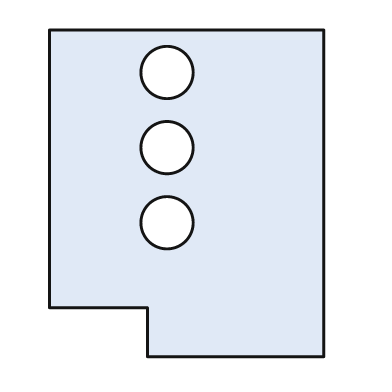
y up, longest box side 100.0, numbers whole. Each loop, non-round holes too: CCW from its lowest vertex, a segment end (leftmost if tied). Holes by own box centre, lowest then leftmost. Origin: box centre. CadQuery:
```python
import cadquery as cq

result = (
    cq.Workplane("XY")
    .moveTo(-12.0, -50.0)
    .lineTo(42.0, -50.0)
    .lineTo(42.0, 50.0)
    .lineTo(-42.0, 50.0)
    .lineTo(-42.0, -35.0)
    .lineTo(-12.0, -35.0)
    .close()
    .moveTo(-6.0, -9.0)
    .circle(8.0)
    .moveTo(-6.0, 14.0)
    .circle(8.0)
    .moveTo(-6.0, 37.0)
    .circle(8.0)
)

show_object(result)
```